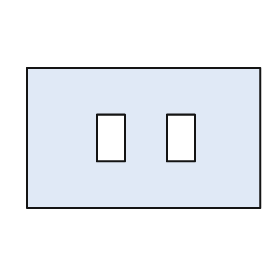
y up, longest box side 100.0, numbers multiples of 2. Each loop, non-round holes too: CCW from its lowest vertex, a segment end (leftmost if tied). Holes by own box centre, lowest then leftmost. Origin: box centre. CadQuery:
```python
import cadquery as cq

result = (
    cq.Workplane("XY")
    .moveTo(-50.0, -30.0)
    .lineTo(50.0, -30.0)
    .lineTo(50.0, 30.0)
    .lineTo(-50.0, 30.0)
    .close()
    .moveTo(-20.0, -10.0)
    .lineTo(-8.0, -10.0)
    .lineTo(-8.0, 10.0)
    .lineTo(-20.0, 10.0)
    .close()
    .moveTo(10.0, -10.0)
    .lineTo(22.0, -10.0)
    .lineTo(22.0, 10.0)
    .lineTo(10.0, 10.0)
    .close()
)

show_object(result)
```